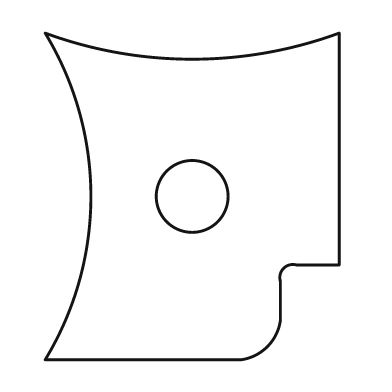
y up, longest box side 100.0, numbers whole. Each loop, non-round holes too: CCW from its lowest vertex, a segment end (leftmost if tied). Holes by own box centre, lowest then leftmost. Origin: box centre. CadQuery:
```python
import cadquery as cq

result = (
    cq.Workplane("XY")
    .moveTo(-45.0, -50.0)
    .lineTo(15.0, -50.0)
    .threePointArc((23.0, -46.0), (27.0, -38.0))
    .lineTo(27.0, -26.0)
    .threePointArc((28.0, -22.0), (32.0, -21.0))
    .lineTo(45.0, -21.0)
    .lineTo(45.0, 50.0)
    .threePointArc((0.0, 42.0), (-45.0, 50.0))
    .threePointArc((-31.0, 0.0), (-45.0, -50.0))
    .close()
    .moveTo(0.0, 0.0)
    .circle(11.0)
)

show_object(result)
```